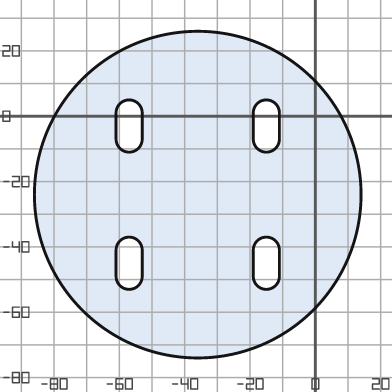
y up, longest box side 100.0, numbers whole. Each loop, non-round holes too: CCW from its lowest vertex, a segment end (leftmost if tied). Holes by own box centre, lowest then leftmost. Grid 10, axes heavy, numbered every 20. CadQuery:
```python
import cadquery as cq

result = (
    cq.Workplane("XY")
    .moveTo(-36.0, -24.0)
    .circle(50.0)
    .moveTo(-61.0, -49.0)
    .threePointArc((-57.0, -53.0), (-53.0, -49.0))
    .lineTo(-53.0, -41.0)
    .threePointArc((-57.0, -37.0), (-61.0, -41.0))
    .close()
    .moveTo(-19.0, -49.0)
    .threePointArc((-15.0, -53.0), (-11.0, -49.0))
    .lineTo(-11.0, -41.0)
    .threePointArc((-15.0, -37.0), (-19.0, -41.0))
    .close()
    .moveTo(-61.0, -7.0)
    .threePointArc((-57.0, -11.0), (-53.0, -7.0))
    .lineTo(-53.0, 1.0)
    .threePointArc((-57.0, 5.0), (-61.0, 1.0))
    .close()
    .moveTo(-19.0, -7.0)
    .threePointArc((-15.0, -11.0), (-11.0, -7.0))
    .lineTo(-11.0, 1.0)
    .threePointArc((-15.0, 5.0), (-19.0, 1.0))
    .close()
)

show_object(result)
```